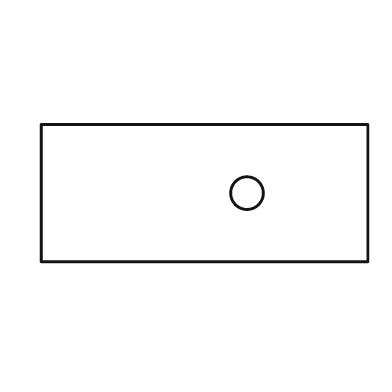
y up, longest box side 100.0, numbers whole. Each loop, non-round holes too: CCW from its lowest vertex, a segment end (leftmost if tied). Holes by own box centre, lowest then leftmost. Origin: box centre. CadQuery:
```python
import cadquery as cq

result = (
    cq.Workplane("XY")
    .moveTo(-50.0, -21.0)
    .lineTo(50.0, -21.0)
    .lineTo(50.0, 21.0)
    .lineTo(-50.0, 21.0)
    .close()
    .moveTo(13.0, 0.0)
    .circle(5.0)
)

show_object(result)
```